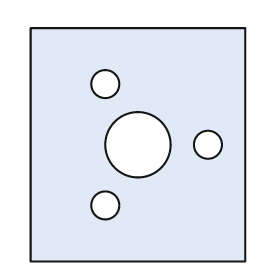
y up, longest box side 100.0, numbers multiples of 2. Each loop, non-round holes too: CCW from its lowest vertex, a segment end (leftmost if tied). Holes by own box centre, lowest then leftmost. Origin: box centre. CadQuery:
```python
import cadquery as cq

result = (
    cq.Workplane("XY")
    .moveTo(-46.0, -50.0)
    .lineTo(46.0, -50.0)
    .lineTo(46.0, 50.0)
    .lineTo(-46.0, 50.0)
    .close()
    .moveTo(-14.0, -26.0)
    .circle(6.0)
    .moveTo(0.0, 0.0)
    .circle(14.0)
    .moveTo(30.0, 0.0)
    .circle(6.0)
    .moveTo(-14.0, 26.0)
    .circle(6.0)
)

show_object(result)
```